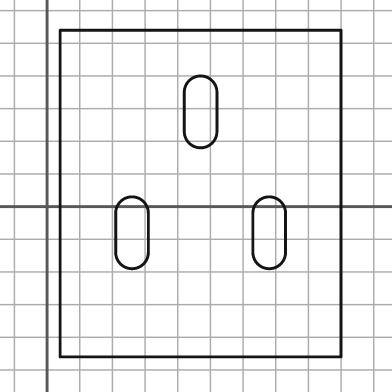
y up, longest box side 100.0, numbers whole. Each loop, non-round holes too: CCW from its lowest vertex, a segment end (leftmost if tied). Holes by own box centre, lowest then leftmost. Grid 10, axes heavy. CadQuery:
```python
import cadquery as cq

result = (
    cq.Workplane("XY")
    .moveTo(4.0, -46.0)
    .lineTo(90.0, -46.0)
    .lineTo(90.0, 54.0)
    .lineTo(4.0, 54.0)
    .close()
    .moveTo(21.0, -14.0)
    .threePointArc((26.0, -19.0), (31.0, -14.0))
    .lineTo(31.0, -2.0)
    .threePointArc((26.0, 3.0), (21.0, -2.0))
    .close()
    .moveTo(63.0, -14.0)
    .threePointArc((68.0, -19.0), (73.0, -14.0))
    .lineTo(73.0, -2.0)
    .threePointArc((68.0, 3.0), (63.0, -2.0))
    .close()
    .moveTo(42.0, 23.0)
    .threePointArc((47.0, 18.0), (52.0, 23.0))
    .lineTo(52.0, 35.0)
    .threePointArc((47.0, 40.0), (42.0, 35.0))
    .close()
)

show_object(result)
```